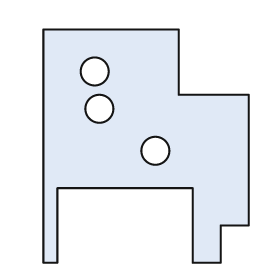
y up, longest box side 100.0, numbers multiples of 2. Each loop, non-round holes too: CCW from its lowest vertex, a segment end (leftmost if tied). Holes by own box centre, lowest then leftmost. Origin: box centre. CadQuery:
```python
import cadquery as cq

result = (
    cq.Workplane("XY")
    .moveTo(-44.0, -50.0)
    .lineTo(-38.0, -50.0)
    .lineTo(-38.0, -18.0)
    .lineTo(20.0, -18.0)
    .lineTo(20.0, -50.0)
    .lineTo(32.0, -50.0)
    .lineTo(32.0, -34.0)
    .lineTo(44.0, -34.0)
    .lineTo(44.0, 22.0)
    .lineTo(14.0, 22.0)
    .lineTo(14.0, 50.0)
    .lineTo(-44.0, 50.0)
    .close()
    .moveTo(4.0, -2.0)
    .circle(6.0)
    .moveTo(-20.0, 16.0)
    .circle(6.0)
    .moveTo(-22.0, 32.0)
    .circle(6.0)
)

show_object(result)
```